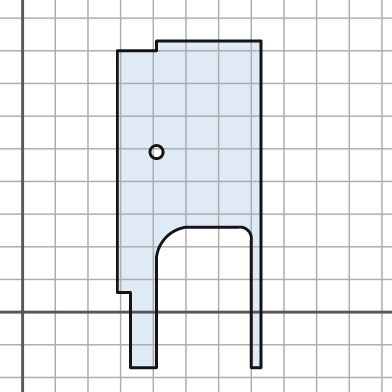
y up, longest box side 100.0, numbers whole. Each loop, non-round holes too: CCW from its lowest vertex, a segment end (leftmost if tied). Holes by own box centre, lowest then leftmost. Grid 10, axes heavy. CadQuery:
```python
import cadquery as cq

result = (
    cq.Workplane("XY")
    .moveTo(33.0, -17.0)
    .lineTo(41.0, -17.0)
    .lineTo(41.0, 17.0)
    .threePointArc((44.0, 23.0), (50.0, 26.0))
    .lineTo(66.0, 26.0)
    .threePointArc((69.0, 25.0), (70.0, 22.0))
    .lineTo(70.0, -17.0)
    .lineTo(73.0, -17.0)
    .lineTo(73.0, 83.0)
    .lineTo(41.0, 83.0)
    .lineTo(41.0, 80.0)
    .lineTo(29.0, 80.0)
    .lineTo(29.0, 6.0)
    .lineTo(33.0, 6.0)
    .close()
    .moveTo(41.0, 49.0)
    .circle(2.0)
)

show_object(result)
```